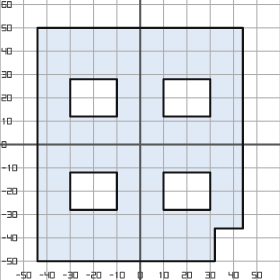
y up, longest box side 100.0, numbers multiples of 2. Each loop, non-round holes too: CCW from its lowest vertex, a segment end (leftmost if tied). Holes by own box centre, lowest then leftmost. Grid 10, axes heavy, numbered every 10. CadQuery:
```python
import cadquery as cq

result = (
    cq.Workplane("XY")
    .moveTo(-44.0, -50.0)
    .lineTo(32.0, -50.0)
    .lineTo(32.0, -36.0)
    .lineTo(44.0, -36.0)
    .lineTo(44.0, 50.0)
    .lineTo(-44.0, 50.0)
    .close()
    .moveTo(-30.0, -28.0)
    .lineTo(-10.0, -28.0)
    .lineTo(-10.0, -12.0)
    .lineTo(-30.0, -12.0)
    .close()
    .moveTo(10.0, -28.0)
    .lineTo(30.0, -28.0)
    .lineTo(30.0, -12.0)
    .lineTo(10.0, -12.0)
    .close()
    .moveTo(-30.0, 12.0)
    .lineTo(-10.0, 12.0)
    .lineTo(-10.0, 28.0)
    .lineTo(-30.0, 28.0)
    .close()
    .moveTo(10.0, 12.0)
    .lineTo(30.0, 12.0)
    .lineTo(30.0, 28.0)
    .lineTo(10.0, 28.0)
    .close()
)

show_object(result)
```